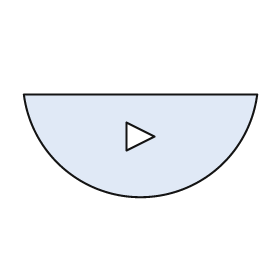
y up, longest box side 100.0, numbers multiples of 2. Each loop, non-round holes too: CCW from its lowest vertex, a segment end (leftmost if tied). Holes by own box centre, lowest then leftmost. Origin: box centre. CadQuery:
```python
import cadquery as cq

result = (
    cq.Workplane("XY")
    .moveTo(-50.0, 22.0)
    .threePointArc((0.0, -22.0), (50.0, 22.0))
    .close()
    .moveTo(-6.0, -2.0)
    .lineTo(6.0, 4.0)
    .lineTo(-6.0, 10.0)
    .close()
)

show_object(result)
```